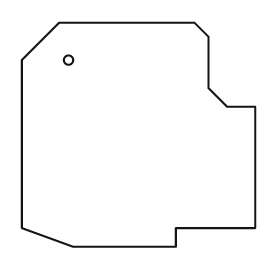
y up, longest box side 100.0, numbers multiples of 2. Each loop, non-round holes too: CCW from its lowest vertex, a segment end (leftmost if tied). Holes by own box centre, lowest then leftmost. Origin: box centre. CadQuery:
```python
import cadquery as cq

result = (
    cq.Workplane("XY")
    .moveTo(-28.0, -48.0)
    .lineTo(16.0, -48.0)
    .lineTo(16.0, -40.0)
    .lineTo(50.0, -40.0)
    .lineTo(50.0, 12.0)
    .lineTo(38.0, 12.0)
    .lineTo(30.0, 20.0)
    .lineTo(30.0, 42.0)
    .lineTo(24.0, 48.0)
    .lineTo(-34.0, 48.0)
    .lineTo(-50.0, 32.0)
    .lineTo(-50.0, -40.0)
    .close()
    .moveTo(-30.0, 32.0)
    .circle(2.0)
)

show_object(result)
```